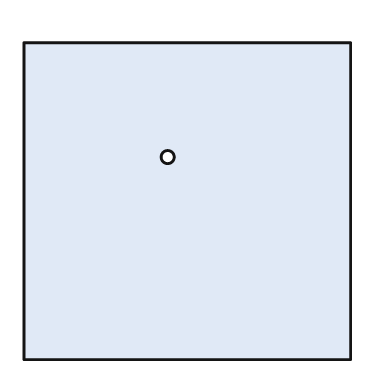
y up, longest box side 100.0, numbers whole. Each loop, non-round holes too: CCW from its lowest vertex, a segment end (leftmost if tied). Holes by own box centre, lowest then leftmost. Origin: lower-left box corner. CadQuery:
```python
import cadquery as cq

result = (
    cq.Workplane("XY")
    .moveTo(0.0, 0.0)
    .lineTo(100.0, 0.0)
    .lineTo(100.0, 97.0)
    .lineTo(0.0, 97.0)
    .close()
    .moveTo(44.0, 62.0)
    .circle(2.0)
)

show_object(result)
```